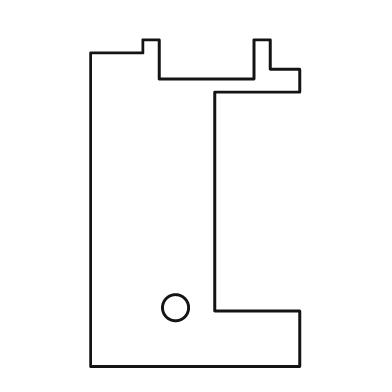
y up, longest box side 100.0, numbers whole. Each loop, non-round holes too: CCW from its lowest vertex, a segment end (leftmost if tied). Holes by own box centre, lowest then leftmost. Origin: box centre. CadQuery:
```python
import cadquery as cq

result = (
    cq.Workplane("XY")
    .moveTo(-32.0, -50.0)
    .lineTo(32.0, -50.0)
    .lineTo(32.0, -33.0)
    .lineTo(6.0, -33.0)
    .lineTo(6.0, 34.0)
    .lineTo(32.0, 34.0)
    .lineTo(32.0, 41.0)
    .lineTo(23.0, 41.0)
    .lineTo(23.0, 50.0)
    .lineTo(18.0, 50.0)
    .lineTo(18.0, 38.0)
    .lineTo(-11.0, 38.0)
    .lineTo(-11.0, 50.0)
    .lineTo(-16.0, 50.0)
    .lineTo(-16.0, 46.0)
    .lineTo(-32.0, 46.0)
    .close()
    .moveTo(-6.0, -32.0)
    .circle(4.0)
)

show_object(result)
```